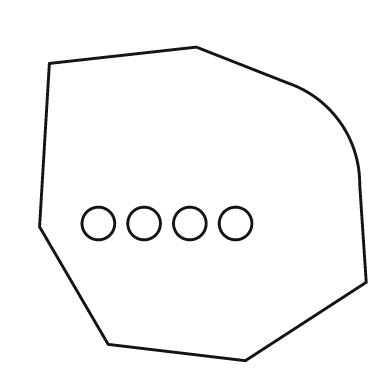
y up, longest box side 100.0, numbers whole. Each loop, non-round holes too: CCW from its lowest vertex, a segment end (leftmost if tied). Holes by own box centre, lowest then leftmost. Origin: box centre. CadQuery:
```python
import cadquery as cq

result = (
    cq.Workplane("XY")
    .moveTo(13.0, -48.0)
    .lineTo(50.0, -24.0)
    .lineTo(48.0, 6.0)
    .threePointArc((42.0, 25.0), (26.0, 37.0))
    .lineTo(-2.0, 48.0)
    .lineTo(-47.0, 43.0)
    .lineTo(-50.0, -7.0)
    .lineTo(-29.0, -43.0)
    .close()
    .moveTo(-32.0, -6.0)
    .circle(5.0)
    .moveTo(-18.0, -6.0)
    .circle(5.0)
    .moveTo(-4.0, -6.0)
    .circle(5.0)
    .moveTo(10.0, -6.0)
    .circle(5.0)
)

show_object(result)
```